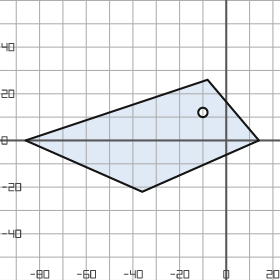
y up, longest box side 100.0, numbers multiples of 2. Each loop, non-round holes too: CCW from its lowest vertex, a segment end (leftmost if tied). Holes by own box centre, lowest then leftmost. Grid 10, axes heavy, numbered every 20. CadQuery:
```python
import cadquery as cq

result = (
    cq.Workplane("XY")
    .moveTo(-36.0, -22.0)
    .lineTo(14.0, 0.0)
    .lineTo(-8.0, 26.0)
    .lineTo(-86.0, 0.0)
    .close()
    .moveTo(-10.0, 12.0)
    .circle(2.0)
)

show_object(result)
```